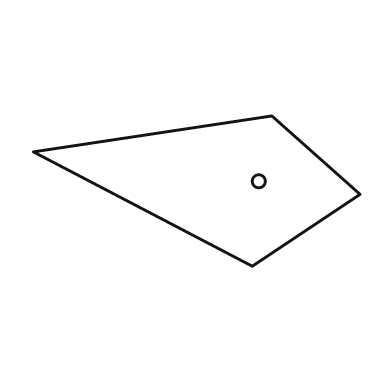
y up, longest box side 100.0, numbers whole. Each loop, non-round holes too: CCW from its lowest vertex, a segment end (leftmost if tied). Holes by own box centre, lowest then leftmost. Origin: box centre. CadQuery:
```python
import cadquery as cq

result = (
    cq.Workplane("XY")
    .moveTo(17.0, -23.0)
    .lineTo(50.0, -1.0)
    .lineTo(23.0, 23.0)
    .lineTo(-50.0, 12.0)
    .close()
    .moveTo(19.0, 3.0)
    .circle(2.0)
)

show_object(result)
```